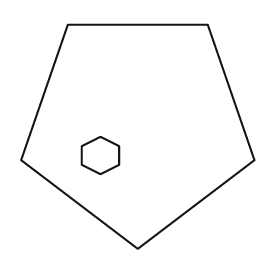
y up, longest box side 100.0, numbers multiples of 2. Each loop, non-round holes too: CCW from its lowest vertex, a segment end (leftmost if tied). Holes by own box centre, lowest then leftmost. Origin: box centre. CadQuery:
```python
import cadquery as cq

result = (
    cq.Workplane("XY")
    .moveTo(0.0, -48.0)
    .lineTo(50.0, -10.0)
    .lineTo(30.0, 48.0)
    .lineTo(-30.0, 48.0)
    .lineTo(-50.0, -10.0)
    .close()
    .moveTo(-16.0, -16.0)
    .lineTo(-8.0, -12.0)
    .lineTo(-8.0, -4.0)
    .lineTo(-16.0, 0.0)
    .lineTo(-24.0, -4.0)
    .lineTo(-24.0, -12.0)
    .close()
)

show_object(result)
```